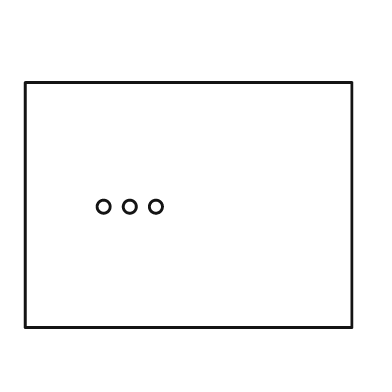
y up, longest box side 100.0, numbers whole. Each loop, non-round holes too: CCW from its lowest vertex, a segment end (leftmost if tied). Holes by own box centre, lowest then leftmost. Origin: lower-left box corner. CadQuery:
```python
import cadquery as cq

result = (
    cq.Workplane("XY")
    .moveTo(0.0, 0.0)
    .lineTo(100.0, 0.0)
    .lineTo(100.0, 75.0)
    .lineTo(0.0, 75.0)
    .close()
    .moveTo(24.0, 37.0)
    .circle(2.0)
    .moveTo(32.0, 37.0)
    .circle(2.0)
    .moveTo(40.0, 37.0)
    .circle(2.0)
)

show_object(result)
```